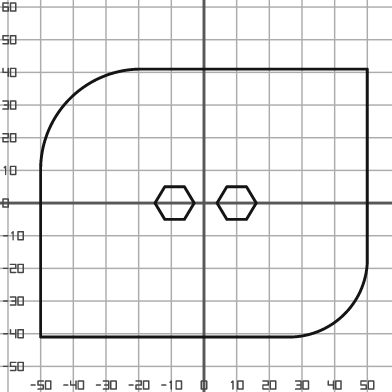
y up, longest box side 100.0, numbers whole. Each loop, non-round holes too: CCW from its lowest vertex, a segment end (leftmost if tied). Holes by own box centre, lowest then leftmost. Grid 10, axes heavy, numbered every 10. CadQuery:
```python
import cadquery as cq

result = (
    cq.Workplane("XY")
    .moveTo(-50.0, -41.0)
    .lineTo(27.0, -41.0)
    .threePointArc((43.0, -34.0), (50.0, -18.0))
    .lineTo(50.0, 41.0)
    .lineTo(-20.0, 41.0)
    .threePointArc((-41.0, 32.0), (-50.0, 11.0))
    .close()
    .moveTo(-12.0, -5.0)
    .lineTo(-6.0, -5.0)
    .lineTo(-3.0, 0.0)
    .lineTo(-6.0, 5.0)
    .lineTo(-12.0, 5.0)
    .lineTo(-15.0, 0.0)
    .close()
    .moveTo(7.0, -5.0)
    .lineTo(13.0, -5.0)
    .lineTo(16.0, 0.0)
    .lineTo(13.0, 5.0)
    .lineTo(7.0, 5.0)
    .lineTo(4.0, 0.0)
    .close()
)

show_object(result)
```